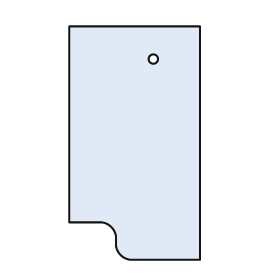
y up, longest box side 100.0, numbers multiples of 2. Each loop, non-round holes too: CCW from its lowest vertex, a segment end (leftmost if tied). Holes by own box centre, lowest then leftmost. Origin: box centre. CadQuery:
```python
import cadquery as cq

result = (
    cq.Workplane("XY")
    .moveTo(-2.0, -50.0)
    .lineTo(28.0, -50.0)
    .lineTo(28.0, 50.0)
    .lineTo(-28.0, 50.0)
    .lineTo(-28.0, -34.0)
    .lineTo(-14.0, -34.0)
    .threePointArc((-10.0, -36.0), (-8.0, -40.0))
    .lineTo(-8.0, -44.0)
    .threePointArc((-6.0, -48.0), (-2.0, -50.0))
    .close()
    .moveTo(8.0, 36.0)
    .circle(2.0)
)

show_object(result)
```